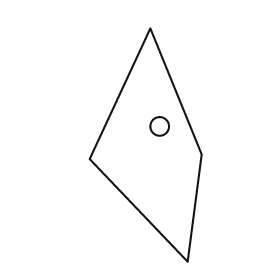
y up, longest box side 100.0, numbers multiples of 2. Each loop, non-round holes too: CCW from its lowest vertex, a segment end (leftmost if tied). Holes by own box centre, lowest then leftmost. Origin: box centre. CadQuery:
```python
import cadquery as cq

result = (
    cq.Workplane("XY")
    .moveTo(18.0, -50.0)
    .lineTo(24.0, -4.0)
    .lineTo(2.0, 50.0)
    .lineTo(-24.0, -6.0)
    .close()
    .moveTo(6.0, 8.0)
    .circle(4.0)
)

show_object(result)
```